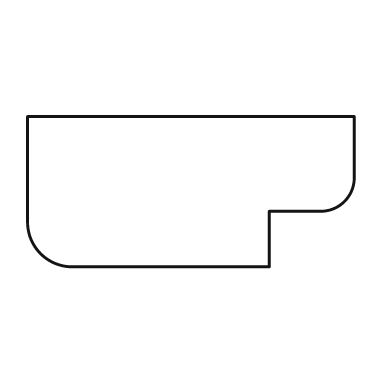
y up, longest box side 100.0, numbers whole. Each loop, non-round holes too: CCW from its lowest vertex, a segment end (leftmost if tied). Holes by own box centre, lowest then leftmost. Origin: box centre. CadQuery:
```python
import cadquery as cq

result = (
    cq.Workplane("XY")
    .moveTo(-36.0, -23.0)
    .lineTo(24.0, -23.0)
    .lineTo(24.0, -6.0)
    .lineTo(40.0, -6.0)
    .threePointArc((47.0, -3.0), (50.0, 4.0))
    .lineTo(50.0, 23.0)
    .lineTo(-50.0, 23.0)
    .lineTo(-50.0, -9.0)
    .threePointArc((-46.0, -19.0), (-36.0, -23.0))
    .close()
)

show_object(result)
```